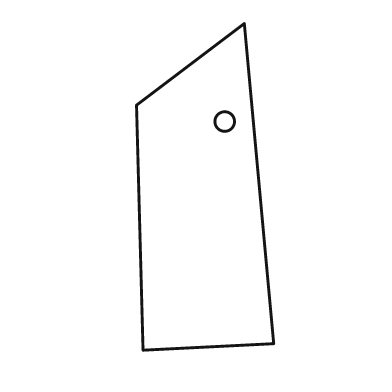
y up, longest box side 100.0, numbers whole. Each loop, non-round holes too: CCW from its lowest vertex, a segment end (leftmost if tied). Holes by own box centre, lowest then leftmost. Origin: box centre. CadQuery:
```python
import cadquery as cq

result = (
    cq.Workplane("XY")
    .moveTo(-19.0, -50.0)
    .lineTo(21.0, -48.0)
    .lineTo(12.0, 50.0)
    .lineTo(-21.0, 25.0)
    .close()
    .moveTo(6.0, 20.0)
    .circle(3.0)
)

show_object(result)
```